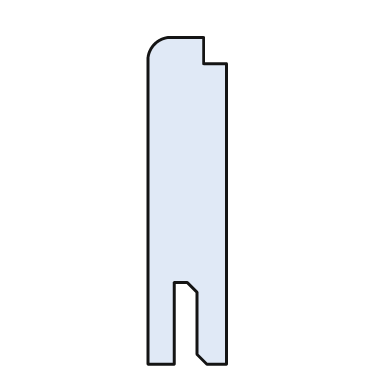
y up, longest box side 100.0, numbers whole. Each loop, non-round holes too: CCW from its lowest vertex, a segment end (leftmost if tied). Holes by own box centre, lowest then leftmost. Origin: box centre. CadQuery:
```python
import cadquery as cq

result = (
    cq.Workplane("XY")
    .moveTo(-12.0, -50.0)
    .lineTo(-4.0, -50.0)
    .lineTo(-4.0, -25.0)
    .lineTo(0.0, -25.0)
    .lineTo(3.0, -28.0)
    .lineTo(3.0, -47.0)
    .lineTo(6.0, -50.0)
    .lineTo(12.0, -50.0)
    .lineTo(12.0, 42.0)
    .lineTo(5.0, 42.0)
    .lineTo(5.0, 50.0)
    .lineTo(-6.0, 50.0)
    .threePointArc((-10.0, 48.0), (-12.0, 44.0))
    .close()
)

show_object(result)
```